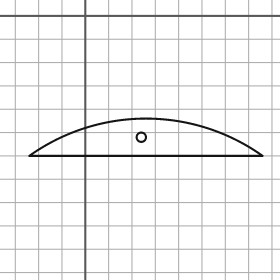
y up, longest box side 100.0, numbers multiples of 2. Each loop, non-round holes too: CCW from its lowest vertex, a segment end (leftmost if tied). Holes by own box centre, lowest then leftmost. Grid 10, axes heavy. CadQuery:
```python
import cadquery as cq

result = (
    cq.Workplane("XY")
    .moveTo(-24.0, -60.0)
    .lineTo(76.0, -60.0)
    .threePointArc((26.0, -44.0), (-24.0, -60.0))
    .close()
    .moveTo(24.0, -52.0)
    .circle(2.0)
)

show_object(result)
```